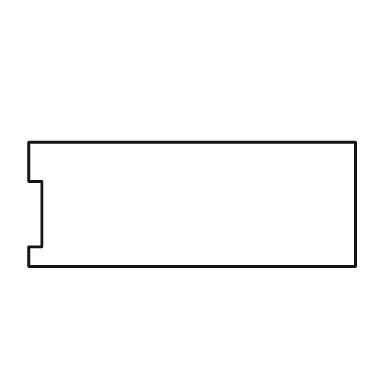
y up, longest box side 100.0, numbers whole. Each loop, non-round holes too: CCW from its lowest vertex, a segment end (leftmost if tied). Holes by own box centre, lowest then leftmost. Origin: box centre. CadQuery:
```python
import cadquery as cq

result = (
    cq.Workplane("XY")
    .moveTo(-50.0, -19.0)
    .lineTo(50.0, -19.0)
    .lineTo(50.0, 19.0)
    .lineTo(-50.0, 19.0)
    .lineTo(-50.0, 7.0)
    .lineTo(-46.0, 7.0)
    .lineTo(-46.0, -13.0)
    .lineTo(-50.0, -13.0)
    .close()
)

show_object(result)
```